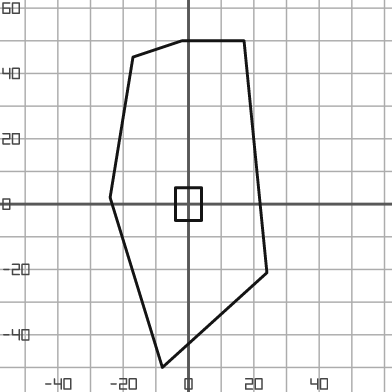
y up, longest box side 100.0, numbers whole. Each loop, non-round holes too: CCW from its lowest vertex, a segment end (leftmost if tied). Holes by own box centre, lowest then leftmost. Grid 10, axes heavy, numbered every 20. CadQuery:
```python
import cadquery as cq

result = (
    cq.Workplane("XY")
    .moveTo(-8.0, -50.0)
    .lineTo(24.0, -21.0)
    .lineTo(17.0, 50.0)
    .lineTo(-2.0, 50.0)
    .lineTo(-17.0, 45.0)
    .lineTo(-24.0, 2.0)
    .close()
    .moveTo(-4.0, -5.0)
    .lineTo(4.0, -5.0)
    .lineTo(4.0, 5.0)
    .lineTo(-4.0, 5.0)
    .close()
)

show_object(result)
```